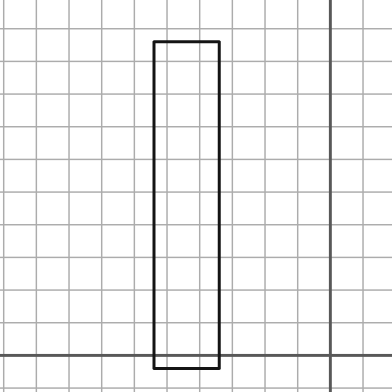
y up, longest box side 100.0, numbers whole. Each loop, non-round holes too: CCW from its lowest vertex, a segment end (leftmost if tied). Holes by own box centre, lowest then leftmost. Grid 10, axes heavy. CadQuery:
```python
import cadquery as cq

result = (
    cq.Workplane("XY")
    .moveTo(-54.0, -4.0)
    .lineTo(-34.0, -4.0)
    .lineTo(-34.0, 96.0)
    .lineTo(-54.0, 96.0)
    .close()
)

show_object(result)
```